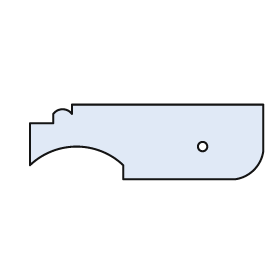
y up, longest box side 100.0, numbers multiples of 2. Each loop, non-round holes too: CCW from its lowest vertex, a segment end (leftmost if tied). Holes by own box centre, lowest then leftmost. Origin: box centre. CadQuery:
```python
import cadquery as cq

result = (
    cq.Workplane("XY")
    .moveTo(-10.0, -16.0)
    .lineTo(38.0, -16.0)
    .threePointArc((46.0, -12.0), (50.0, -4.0))
    .lineTo(50.0, 16.0)
    .lineTo(-32.0, 16.0)
    .lineTo(-32.0, 12.0)
    .threePointArc((-36.0, 14.0), (-40.0, 12.0))
    .lineTo(-40.0, 8.0)
    .lineTo(-50.0, 8.0)
    .lineTo(-50.0, -10.0)
    .threePointArc((-30.0, -2.0), (-10.0, -10.0))
    .close()
    .moveTo(24.0, -2.0)
    .circle(2.0)
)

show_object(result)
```